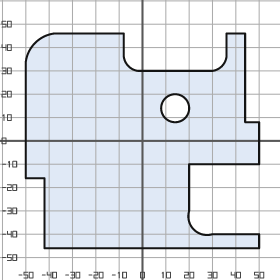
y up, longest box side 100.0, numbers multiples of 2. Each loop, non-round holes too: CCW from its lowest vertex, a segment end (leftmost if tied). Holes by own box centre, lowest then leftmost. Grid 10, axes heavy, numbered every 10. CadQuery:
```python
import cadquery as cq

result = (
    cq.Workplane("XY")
    .moveTo(-42.0, -46.0)
    .lineTo(50.0, -46.0)
    .lineTo(50.0, -40.0)
    .lineTo(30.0, -40.0)
    .threePointArc((22.0, -38.0), (20.0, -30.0))
    .lineTo(20.0, -10.0)
    .lineTo(50.0, -10.0)
    .lineTo(50.0, 8.0)
    .lineTo(44.0, 8.0)
    .lineTo(44.0, 46.0)
    .lineTo(36.0, 46.0)
    .lineTo(36.0, 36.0)
    .threePointArc((34.0, 32.0), (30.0, 30.0))
    .lineTo(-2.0, 30.0)
    .threePointArc((-6.0, 32.0), (-8.0, 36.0))
    .lineTo(-8.0, 46.0)
    .lineTo(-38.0, 46.0)
    .threePointArc((-46.0, 42.0), (-50.0, 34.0))
    .lineTo(-50.0, -16.0)
    .lineTo(-42.0, -16.0)
    .close()
    .moveTo(14.0, 14.0)
    .circle(6.0)
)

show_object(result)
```